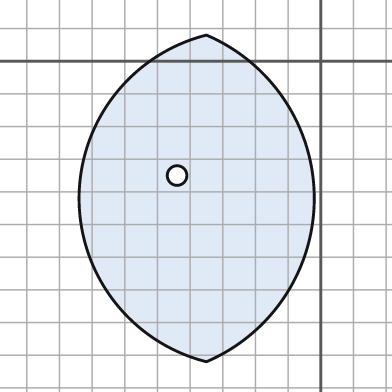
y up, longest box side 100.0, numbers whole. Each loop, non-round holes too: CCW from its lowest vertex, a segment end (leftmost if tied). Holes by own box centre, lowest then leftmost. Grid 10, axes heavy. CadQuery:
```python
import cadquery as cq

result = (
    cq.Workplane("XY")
    .moveTo(-35.0, -92.0)
    .threePointArc((-2.0, -42.0), (-35.0, 8.0))
    .threePointArc((-74.0, -42.0), (-35.0, -92.0))
    .close()
    .moveTo(-44.0, -35.0)
    .circle(3.0)
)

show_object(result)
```